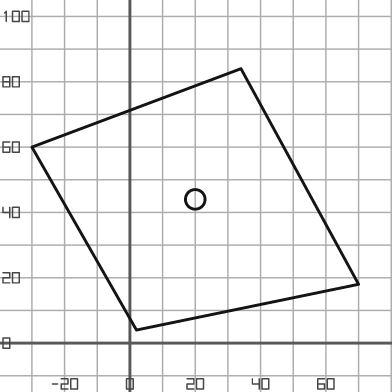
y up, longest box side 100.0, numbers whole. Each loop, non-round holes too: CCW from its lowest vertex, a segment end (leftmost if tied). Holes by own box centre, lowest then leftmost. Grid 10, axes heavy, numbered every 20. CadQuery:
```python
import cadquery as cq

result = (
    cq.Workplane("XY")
    .moveTo(2.0, 4.0)
    .lineTo(70.0, 18.0)
    .lineTo(34.0, 84.0)
    .lineTo(-30.0, 60.0)
    .close()
    .moveTo(20.0, 44.0)
    .circle(3.0)
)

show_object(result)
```